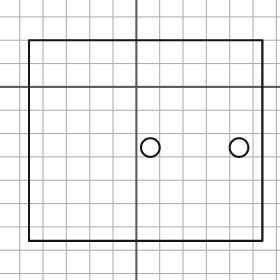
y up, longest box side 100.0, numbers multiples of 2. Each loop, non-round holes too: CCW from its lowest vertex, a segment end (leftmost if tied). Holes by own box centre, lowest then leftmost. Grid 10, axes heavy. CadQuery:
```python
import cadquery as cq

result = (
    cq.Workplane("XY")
    .moveTo(-46.0, -66.0)
    .lineTo(54.0, -66.0)
    .lineTo(54.0, 20.0)
    .lineTo(-46.0, 20.0)
    .close()
    .moveTo(6.0, -26.0)
    .circle(4.0)
    .moveTo(44.0, -26.0)
    .circle(4.0)
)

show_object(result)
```